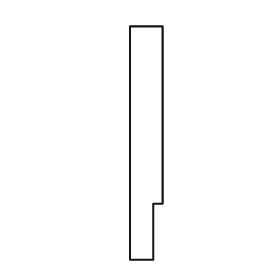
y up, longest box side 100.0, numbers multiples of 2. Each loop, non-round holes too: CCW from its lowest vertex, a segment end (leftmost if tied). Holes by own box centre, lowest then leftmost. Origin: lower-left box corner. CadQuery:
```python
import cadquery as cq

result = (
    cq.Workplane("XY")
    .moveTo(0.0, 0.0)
    .lineTo(10.0, 0.0)
    .lineTo(10.0, 24.0)
    .lineTo(14.0, 24.0)
    .lineTo(14.0, 100.0)
    .lineTo(0.0, 100.0)
    .close()
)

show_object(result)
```